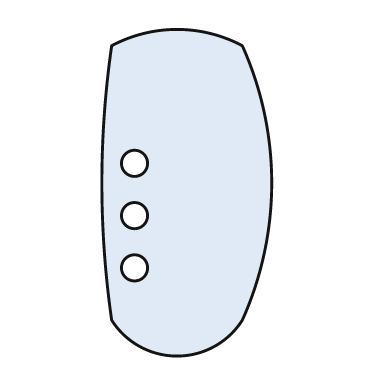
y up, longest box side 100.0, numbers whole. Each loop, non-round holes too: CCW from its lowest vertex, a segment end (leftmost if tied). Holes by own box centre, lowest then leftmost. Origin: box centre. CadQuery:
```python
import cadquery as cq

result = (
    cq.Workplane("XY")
    .moveTo(-23.0, -39.0)
    .threePointArc((-3.0, -50.0), (17.0, -39.0))
    .threePointArc((26.0, 3.0), (17.0, 45.0))
    .threePointArc((-3.0, 50.0), (-23.0, 45.0))
    .threePointArc((-26.0, 3.0), (-23.0, -39.0))
    .close()
    .moveTo(-16.0, -23.0)
    .circle(4.0)
    .moveTo(-16.0, -7.0)
    .circle(4.0)
    .moveTo(-16.0, 9.0)
    .circle(4.0)
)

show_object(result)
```